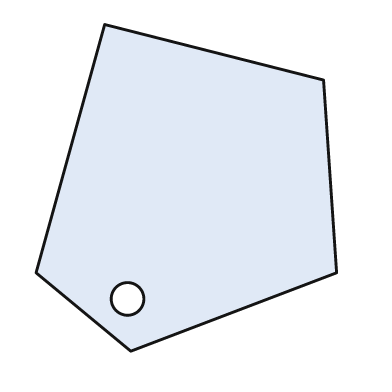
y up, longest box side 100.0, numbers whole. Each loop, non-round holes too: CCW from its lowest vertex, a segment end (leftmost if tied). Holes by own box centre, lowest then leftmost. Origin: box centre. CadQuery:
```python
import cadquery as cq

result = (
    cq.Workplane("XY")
    .moveTo(-17.0, -50.0)
    .lineTo(46.0, -26.0)
    .lineTo(42.0, 33.0)
    .lineTo(-25.0, 50.0)
    .lineTo(-46.0, -26.0)
    .close()
    .moveTo(-18.0, -34.0)
    .circle(5.0)
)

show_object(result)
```